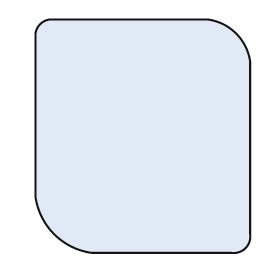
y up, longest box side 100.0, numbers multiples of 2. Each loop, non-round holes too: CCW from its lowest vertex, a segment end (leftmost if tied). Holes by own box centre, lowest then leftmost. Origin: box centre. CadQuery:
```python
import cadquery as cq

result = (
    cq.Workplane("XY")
    .moveTo(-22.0, -50.0)
    .lineTo(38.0, -50.0)
    .threePointArc((44.0, -48.0), (46.0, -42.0))
    .lineTo(46.0, 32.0)
    .threePointArc((40.0, 44.0), (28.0, 50.0))
    .lineTo(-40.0, 50.0)
    .threePointArc((-44.0, 48.0), (-46.0, 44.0))
    .lineTo(-46.0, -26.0)
    .threePointArc((-38.0, -42.0), (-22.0, -50.0))
    .close()
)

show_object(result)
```